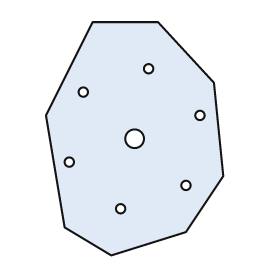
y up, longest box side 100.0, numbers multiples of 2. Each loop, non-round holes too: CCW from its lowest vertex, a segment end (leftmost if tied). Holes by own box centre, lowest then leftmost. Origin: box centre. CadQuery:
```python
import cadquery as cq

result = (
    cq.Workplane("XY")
    .moveTo(-10.0, -50.0)
    .lineTo(22.0, -40.0)
    .lineTo(38.0, -16.0)
    .lineTo(34.0, 24.0)
    .lineTo(10.0, 50.0)
    .lineTo(-18.0, 50.0)
    .lineTo(-38.0, 10.0)
    .lineTo(-30.0, -38.0)
    .close()
    .moveTo(-6.0, -30.0)
    .circle(2.0)
    .moveTo(22.0, -20.0)
    .circle(2.0)
    .moveTo(-28.0, -10.0)
    .circle(2.0)
    .moveTo(0.0, 0.0)
    .circle(4.0)
    .moveTo(28.0, 10.0)
    .circle(2.0)
    .moveTo(-22.0, 20.0)
    .circle(2.0)
    .moveTo(6.0, 30.0)
    .circle(2.0)
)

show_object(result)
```